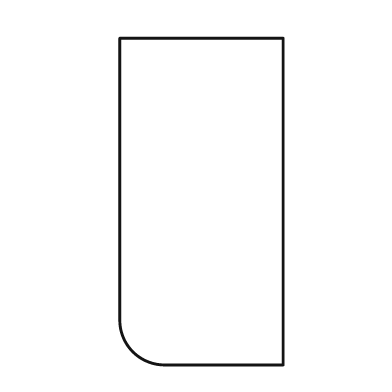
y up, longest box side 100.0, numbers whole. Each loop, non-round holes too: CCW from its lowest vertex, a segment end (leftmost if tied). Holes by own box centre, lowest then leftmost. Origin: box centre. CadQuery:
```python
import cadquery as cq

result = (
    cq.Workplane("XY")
    .moveTo(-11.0, -50.0)
    .lineTo(25.0, -50.0)
    .lineTo(25.0, 50.0)
    .lineTo(-25.0, 50.0)
    .lineTo(-25.0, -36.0)
    .threePointArc((-21.0, -46.0), (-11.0, -50.0))
    .close()
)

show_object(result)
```